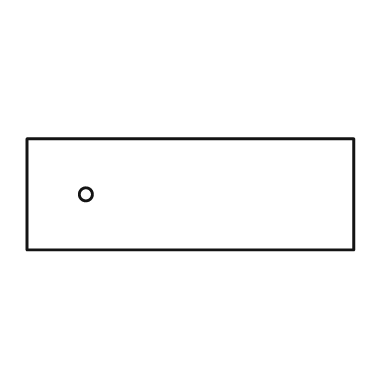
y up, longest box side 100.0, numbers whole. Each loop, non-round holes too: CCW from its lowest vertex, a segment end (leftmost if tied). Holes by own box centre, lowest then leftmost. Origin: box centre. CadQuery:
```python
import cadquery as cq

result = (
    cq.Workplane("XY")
    .moveTo(-50.0, -17.0)
    .lineTo(50.0, -17.0)
    .lineTo(50.0, 17.0)
    .lineTo(-50.0, 17.0)
    .close()
    .moveTo(-32.0, 0.0)
    .circle(2.0)
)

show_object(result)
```